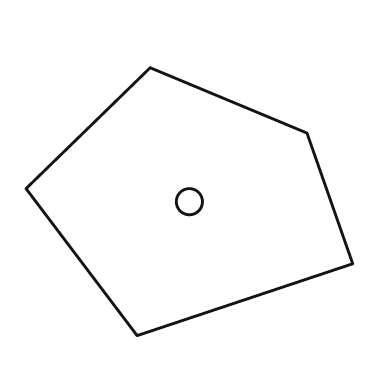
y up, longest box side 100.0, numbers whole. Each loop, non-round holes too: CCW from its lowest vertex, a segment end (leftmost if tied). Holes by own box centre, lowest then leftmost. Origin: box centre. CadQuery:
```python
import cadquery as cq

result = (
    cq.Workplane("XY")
    .moveTo(-16.0, -41.0)
    .lineTo(50.0, -19.0)
    .lineTo(36.0, 21.0)
    .lineTo(-12.0, 41.0)
    .lineTo(-50.0, 4.0)
    .close()
    .moveTo(0.0, 0.0)
    .circle(4.0)
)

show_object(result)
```